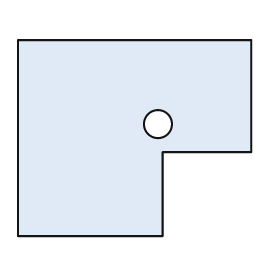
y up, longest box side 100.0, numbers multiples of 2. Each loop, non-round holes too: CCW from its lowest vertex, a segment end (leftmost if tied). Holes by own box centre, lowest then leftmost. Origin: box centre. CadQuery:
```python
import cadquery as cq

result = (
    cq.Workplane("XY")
    .moveTo(-50.0, -42.0)
    .lineTo(12.0, -42.0)
    .lineTo(12.0, -6.0)
    .lineTo(50.0, -6.0)
    .lineTo(50.0, 42.0)
    .lineTo(-50.0, 42.0)
    .close()
    .moveTo(10.0, 6.0)
    .circle(6.0)
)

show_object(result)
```